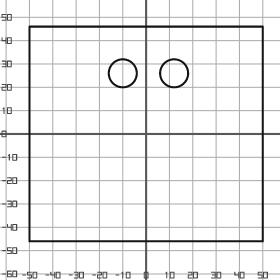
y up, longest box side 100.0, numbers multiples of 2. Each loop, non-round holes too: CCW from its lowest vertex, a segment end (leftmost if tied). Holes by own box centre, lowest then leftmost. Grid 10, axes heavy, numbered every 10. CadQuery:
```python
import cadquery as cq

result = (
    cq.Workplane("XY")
    .moveTo(-50.0, -46.0)
    .lineTo(50.0, -46.0)
    .lineTo(50.0, 46.0)
    .lineTo(-50.0, 46.0)
    .close()
    .moveTo(-10.0, 26.0)
    .circle(6.0)
    .moveTo(12.0, 26.0)
    .circle(6.0)
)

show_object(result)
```